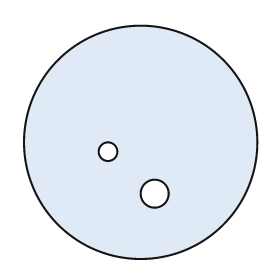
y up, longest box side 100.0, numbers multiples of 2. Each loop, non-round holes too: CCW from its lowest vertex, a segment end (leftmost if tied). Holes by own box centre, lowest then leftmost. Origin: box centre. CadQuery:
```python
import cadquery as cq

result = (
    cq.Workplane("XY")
    .moveTo(0.0, 0.0)
    .circle(50.0)
    .moveTo(6.0, -22.0)
    .circle(6.0)
    .moveTo(-14.0, -4.0)
    .circle(4.0)
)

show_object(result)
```